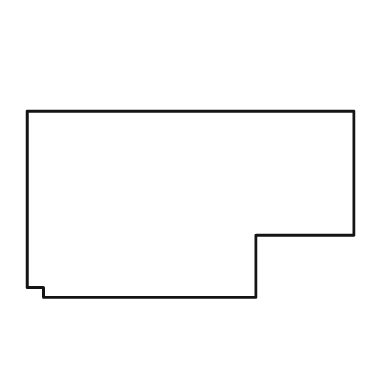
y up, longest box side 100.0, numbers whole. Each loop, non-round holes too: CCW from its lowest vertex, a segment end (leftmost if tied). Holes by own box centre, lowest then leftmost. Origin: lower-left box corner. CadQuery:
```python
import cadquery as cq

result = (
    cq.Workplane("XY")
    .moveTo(5.0, 0.0)
    .lineTo(70.0, 0.0)
    .lineTo(70.0, 19.0)
    .lineTo(100.0, 19.0)
    .lineTo(100.0, 57.0)
    .lineTo(0.0, 57.0)
    .lineTo(0.0, 3.0)
    .lineTo(5.0, 3.0)
    .close()
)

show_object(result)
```